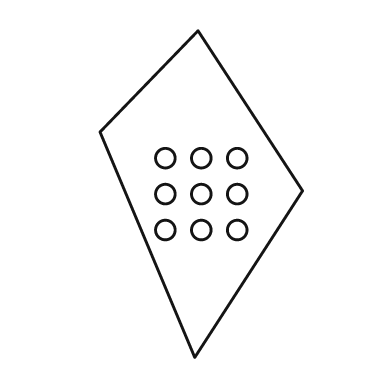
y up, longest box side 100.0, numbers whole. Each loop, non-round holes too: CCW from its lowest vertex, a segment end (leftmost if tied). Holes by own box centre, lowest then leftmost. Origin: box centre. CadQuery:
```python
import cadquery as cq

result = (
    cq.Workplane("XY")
    .moveTo(-2.0, -50.0)
    .lineTo(31.0, 1.0)
    .lineTo(-1.0, 50.0)
    .lineTo(-31.0, 19.0)
    .close()
    .moveTo(-11.0, -11.0)
    .circle(3.0)
    .moveTo(0.0, -11.0)
    .circle(3.0)
    .moveTo(11.0, -11.0)
    .circle(3.0)
    .moveTo(-11.0, 0.0)
    .circle(3.0)
    .moveTo(0.0, 0.0)
    .circle(3.0)
    .moveTo(11.0, 0.0)
    .circle(3.0)
    .moveTo(-11.0, 11.0)
    .circle(3.0)
    .moveTo(0.0, 11.0)
    .circle(3.0)
    .moveTo(11.0, 11.0)
    .circle(3.0)
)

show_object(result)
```